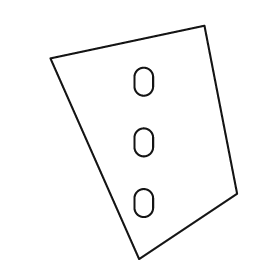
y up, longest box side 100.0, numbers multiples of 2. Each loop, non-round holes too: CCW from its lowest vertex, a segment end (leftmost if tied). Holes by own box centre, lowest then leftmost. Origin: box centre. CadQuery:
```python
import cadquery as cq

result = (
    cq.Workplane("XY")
    .moveTo(-2.0, -50.0)
    .lineTo(40.0, -22.0)
    .lineTo(26.0, 50.0)
    .lineTo(-40.0, 36.0)
    .close()
    .moveTo(-4.0, -28.0)
    .threePointArc((0.0, -32.0), (4.0, -28.0))
    .lineTo(4.0, -24.0)
    .threePointArc((0.0, -20.0), (-4.0, -24.0))
    .close()
    .moveTo(-4.0, -2.0)
    .threePointArc((0.0, -6.0), (4.0, -2.0))
    .lineTo(4.0, 2.0)
    .threePointArc((0.0, 6.0), (-4.0, 2.0))
    .close()
    .moveTo(-4.0, 24.0)
    .threePointArc((0.0, 20.0), (4.0, 24.0))
    .lineTo(4.0, 28.0)
    .threePointArc((0.0, 32.0), (-4.0, 28.0))
    .close()
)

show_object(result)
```